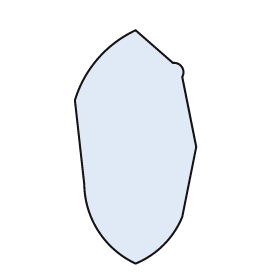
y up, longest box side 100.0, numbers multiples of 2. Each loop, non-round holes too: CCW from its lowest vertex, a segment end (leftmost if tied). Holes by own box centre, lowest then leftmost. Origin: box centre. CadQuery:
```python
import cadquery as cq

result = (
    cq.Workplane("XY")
    .moveTo(0.0, -50.0)
    .threePointArc((12.0, -42.0), (20.0, -30.0))
    .lineTo(26.0, 0.0)
    .lineTo(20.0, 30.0)
    .threePointArc((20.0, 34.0), (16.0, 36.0))
    .lineTo(0.0, 50.0)
    .threePointArc((-16.0, 38.0), (-26.0, 20.0))
    .lineTo(-22.0, -16.0)
    .threePointArc((-16.0, -36.0), (0.0, -50.0))
    .close()
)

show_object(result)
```